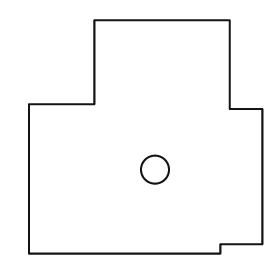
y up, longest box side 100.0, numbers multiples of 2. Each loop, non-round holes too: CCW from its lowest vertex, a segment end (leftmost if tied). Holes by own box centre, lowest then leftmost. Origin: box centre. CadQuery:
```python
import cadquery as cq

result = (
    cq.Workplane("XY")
    .moveTo(-50.0, -50.0)
    .lineTo(32.0, -50.0)
    .lineTo(32.0, -46.0)
    .lineTo(50.0, -46.0)
    .lineTo(50.0, 12.0)
    .lineTo(36.0, 12.0)
    .lineTo(36.0, 50.0)
    .lineTo(-22.0, 50.0)
    .lineTo(-22.0, 14.0)
    .lineTo(-50.0, 14.0)
    .close()
    .moveTo(4.0, -14.0)
    .circle(6.0)
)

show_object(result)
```